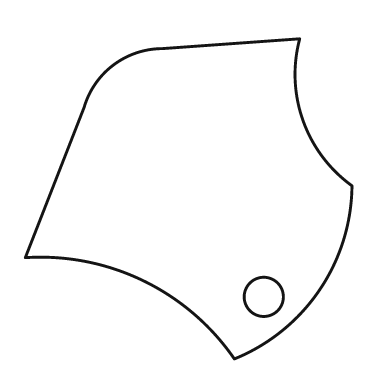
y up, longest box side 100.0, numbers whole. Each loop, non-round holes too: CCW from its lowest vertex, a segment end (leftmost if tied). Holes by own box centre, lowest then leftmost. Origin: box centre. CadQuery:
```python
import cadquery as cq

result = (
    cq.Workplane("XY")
    .moveTo(14.0, -49.0)
    .threePointArc((40.0, -28.0), (50.0, 4.0))
    .threePointArc((35.0, 24.0), (34.0, 49.0))
    .lineTo(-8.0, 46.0)
    .threePointArc((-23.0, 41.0), (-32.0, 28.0))
    .lineTo(-50.0, -18.0)
    .threePointArc((-14.0, -25.0), (14.0, -49.0))
    .close()
    .moveTo(23.0, -30.0)
    .circle(6.0)
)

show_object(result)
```